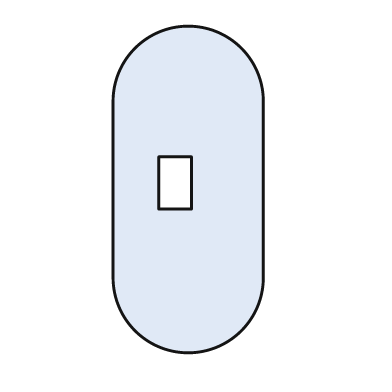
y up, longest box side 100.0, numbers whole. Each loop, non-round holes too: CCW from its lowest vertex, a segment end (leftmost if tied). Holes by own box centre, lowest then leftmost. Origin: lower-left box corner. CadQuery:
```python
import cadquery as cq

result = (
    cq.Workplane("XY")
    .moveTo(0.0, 23.0)
    .threePointArc((23.0, 0.0), (46.0, 23.0))
    .lineTo(46.0, 77.0)
    .threePointArc((23.0, 100.0), (0.0, 77.0))
    .close()
    .moveTo(14.0, 44.0)
    .lineTo(24.0, 44.0)
    .lineTo(24.0, 60.0)
    .lineTo(14.0, 60.0)
    .close()
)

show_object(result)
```